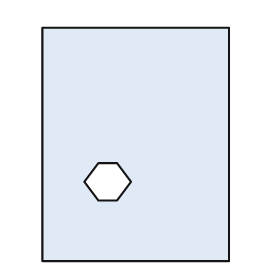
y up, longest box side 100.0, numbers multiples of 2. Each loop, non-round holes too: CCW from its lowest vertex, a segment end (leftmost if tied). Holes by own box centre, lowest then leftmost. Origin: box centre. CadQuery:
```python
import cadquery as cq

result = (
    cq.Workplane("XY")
    .moveTo(-40.0, -50.0)
    .lineTo(40.0, -50.0)
    .lineTo(40.0, 50.0)
    .lineTo(-40.0, 50.0)
    .close()
    .moveTo(-16.0, -24.0)
    .lineTo(-8.0, -24.0)
    .lineTo(-2.0, -16.0)
    .lineTo(-8.0, -8.0)
    .lineTo(-16.0, -8.0)
    .lineTo(-22.0, -16.0)
    .close()
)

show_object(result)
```